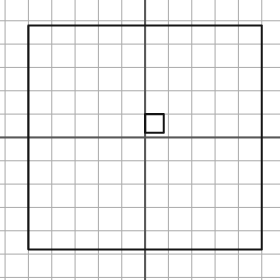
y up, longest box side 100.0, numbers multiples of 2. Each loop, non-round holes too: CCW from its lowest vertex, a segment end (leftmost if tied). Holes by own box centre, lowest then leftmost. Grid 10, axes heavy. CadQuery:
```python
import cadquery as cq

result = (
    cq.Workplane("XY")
    .moveTo(-50.0, -48.0)
    .lineTo(50.0, -48.0)
    .lineTo(50.0, 48.0)
    .lineTo(-50.0, 48.0)
    .close()
    .moveTo(0.0, 2.0)
    .lineTo(8.0, 2.0)
    .lineTo(8.0, 10.0)
    .lineTo(0.0, 10.0)
    .close()
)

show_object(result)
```